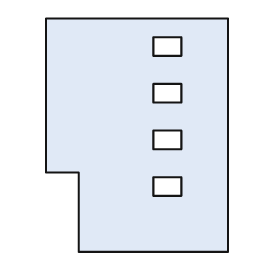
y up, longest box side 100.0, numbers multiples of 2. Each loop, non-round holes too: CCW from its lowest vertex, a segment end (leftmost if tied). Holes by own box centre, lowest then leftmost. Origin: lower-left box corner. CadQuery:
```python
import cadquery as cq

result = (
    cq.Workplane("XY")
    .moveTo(14.0, 0.0)
    .lineTo(78.0, 0.0)
    .lineTo(78.0, 100.0)
    .lineTo(0.0, 100.0)
    .lineTo(0.0, 34.0)
    .lineTo(14.0, 34.0)
    .close()
    .moveTo(46.0, 24.0)
    .lineTo(58.0, 24.0)
    .lineTo(58.0, 32.0)
    .lineTo(46.0, 32.0)
    .close()
    .moveTo(46.0, 44.0)
    .lineTo(58.0, 44.0)
    .lineTo(58.0, 52.0)
    .lineTo(46.0, 52.0)
    .close()
    .moveTo(46.0, 64.0)
    .lineTo(58.0, 64.0)
    .lineTo(58.0, 72.0)
    .lineTo(46.0, 72.0)
    .close()
    .moveTo(46.0, 84.0)
    .lineTo(58.0, 84.0)
    .lineTo(58.0, 92.0)
    .lineTo(46.0, 92.0)
    .close()
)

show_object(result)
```